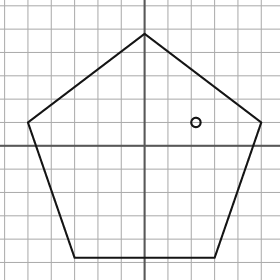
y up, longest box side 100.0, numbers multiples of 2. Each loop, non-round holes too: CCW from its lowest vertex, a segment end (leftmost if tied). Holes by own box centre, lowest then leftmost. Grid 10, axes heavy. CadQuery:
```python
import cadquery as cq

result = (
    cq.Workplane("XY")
    .moveTo(-30.0, -48.0)
    .lineTo(30.0, -48.0)
    .lineTo(50.0, 10.0)
    .lineTo(0.0, 48.0)
    .lineTo(-50.0, 10.0)
    .close()
    .moveTo(22.0, 10.0)
    .circle(2.0)
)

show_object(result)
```